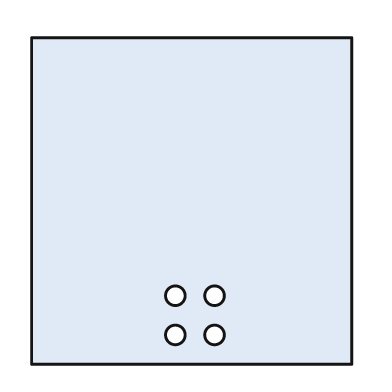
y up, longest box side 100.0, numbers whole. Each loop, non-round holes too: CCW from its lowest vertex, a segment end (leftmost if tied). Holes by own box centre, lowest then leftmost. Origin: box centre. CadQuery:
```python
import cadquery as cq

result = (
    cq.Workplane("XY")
    .moveTo(-49.0, -50.0)
    .lineTo(49.0, -50.0)
    .lineTo(49.0, 50.0)
    .lineTo(-49.0, 50.0)
    .close()
    .moveTo(-5.0, -41.0)
    .circle(3.0)
    .moveTo(7.0, -41.0)
    .circle(3.0)
    .moveTo(-5.0, -29.0)
    .circle(3.0)
    .moveTo(7.0, -29.0)
    .circle(3.0)
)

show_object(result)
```